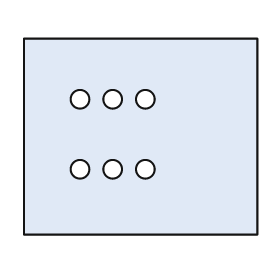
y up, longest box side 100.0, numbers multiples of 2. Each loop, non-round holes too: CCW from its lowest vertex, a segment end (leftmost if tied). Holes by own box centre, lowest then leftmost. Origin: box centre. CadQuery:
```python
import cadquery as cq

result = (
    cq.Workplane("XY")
    .moveTo(-50.0, -42.0)
    .lineTo(50.0, -42.0)
    .lineTo(50.0, 42.0)
    .lineTo(-50.0, 42.0)
    .close()
    .moveTo(-26.0, -14.0)
    .circle(4.0)
    .moveTo(-12.0, -14.0)
    .circle(4.0)
    .moveTo(2.0, -14.0)
    .circle(4.0)
    .moveTo(-26.0, 16.0)
    .circle(4.0)
    .moveTo(-12.0, 16.0)
    .circle(4.0)
    .moveTo(2.0, 16.0)
    .circle(4.0)
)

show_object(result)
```